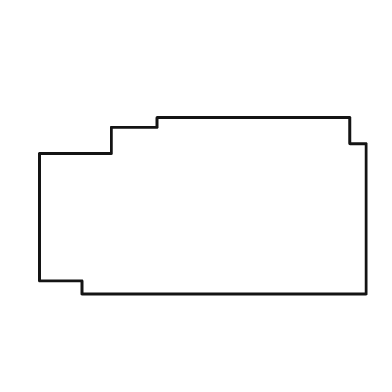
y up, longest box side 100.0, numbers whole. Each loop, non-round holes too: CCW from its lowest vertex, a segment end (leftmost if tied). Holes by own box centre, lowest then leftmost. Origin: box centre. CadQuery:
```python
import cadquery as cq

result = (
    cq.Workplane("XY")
    .moveTo(-37.0, -27.0)
    .lineTo(50.0, -27.0)
    .lineTo(50.0, 19.0)
    .lineTo(45.0, 19.0)
    .lineTo(45.0, 27.0)
    .lineTo(-14.0, 27.0)
    .lineTo(-14.0, 24.0)
    .lineTo(-28.0, 24.0)
    .lineTo(-28.0, 16.0)
    .lineTo(-50.0, 16.0)
    .lineTo(-50.0, -23.0)
    .lineTo(-37.0, -23.0)
    .close()
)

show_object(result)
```